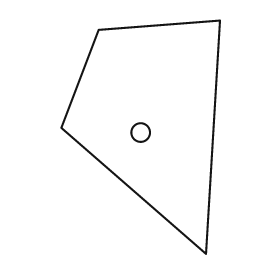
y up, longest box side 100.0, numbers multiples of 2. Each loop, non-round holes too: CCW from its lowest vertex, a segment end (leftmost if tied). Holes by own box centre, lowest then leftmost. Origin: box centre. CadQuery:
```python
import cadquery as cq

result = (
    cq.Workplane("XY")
    .moveTo(28.0, -50.0)
    .lineTo(34.0, 50.0)
    .lineTo(-18.0, 46.0)
    .lineTo(-34.0, 4.0)
    .close()
    .moveTo(0.0, 2.0)
    .circle(4.0)
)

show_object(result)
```